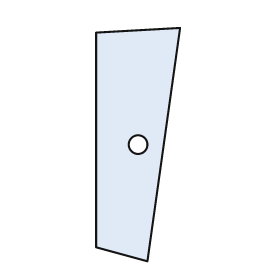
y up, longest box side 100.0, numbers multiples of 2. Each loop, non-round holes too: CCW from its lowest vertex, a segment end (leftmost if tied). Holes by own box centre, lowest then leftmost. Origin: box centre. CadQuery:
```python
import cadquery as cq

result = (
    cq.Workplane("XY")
    .moveTo(4.0, -50.0)
    .lineTo(18.0, 50.0)
    .lineTo(-18.0, 48.0)
    .lineTo(-18.0, -44.0)
    .close()
    .moveTo(0.0, 0.0)
    .circle(4.0)
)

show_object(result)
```